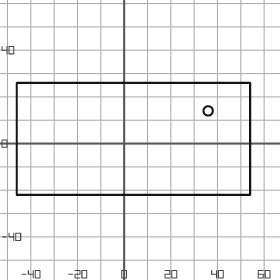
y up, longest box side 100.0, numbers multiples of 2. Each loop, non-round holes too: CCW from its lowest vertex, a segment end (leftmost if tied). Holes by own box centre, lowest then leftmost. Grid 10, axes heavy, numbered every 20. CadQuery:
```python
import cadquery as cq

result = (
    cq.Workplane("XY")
    .moveTo(-46.0, -22.0)
    .lineTo(54.0, -22.0)
    .lineTo(54.0, 26.0)
    .lineTo(-46.0, 26.0)
    .close()
    .moveTo(36.0, 14.0)
    .circle(2.0)
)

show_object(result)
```